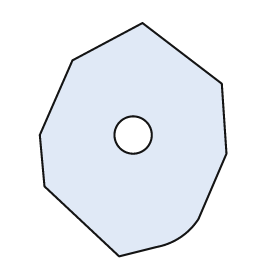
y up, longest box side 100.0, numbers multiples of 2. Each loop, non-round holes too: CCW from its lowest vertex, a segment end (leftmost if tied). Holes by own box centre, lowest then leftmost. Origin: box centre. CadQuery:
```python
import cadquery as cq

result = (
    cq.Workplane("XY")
    .moveTo(-6.0, -50.0)
    .lineTo(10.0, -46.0)
    .threePointArc((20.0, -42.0), (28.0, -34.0))
    .lineTo(40.0, -6.0)
    .lineTo(38.0, 24.0)
    .lineTo(4.0, 50.0)
    .lineTo(-26.0, 34.0)
    .lineTo(-40.0, 2.0)
    .lineTo(-38.0, -20.0)
    .close()
    .moveTo(0.0, 2.0)
    .circle(8.0)
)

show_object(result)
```